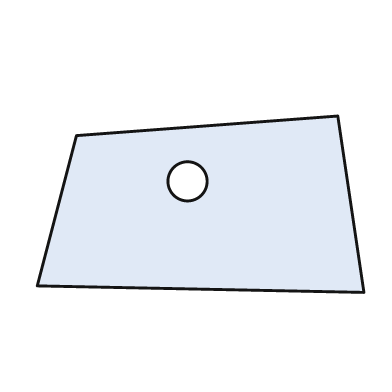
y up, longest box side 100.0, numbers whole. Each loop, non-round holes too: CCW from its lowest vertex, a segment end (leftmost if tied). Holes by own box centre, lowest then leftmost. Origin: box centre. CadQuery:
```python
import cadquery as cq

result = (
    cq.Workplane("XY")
    .moveTo(50.0, -27.0)
    .lineTo(42.0, 27.0)
    .lineTo(-38.0, 21.0)
    .lineTo(-50.0, -25.0)
    .close()
    .moveTo(-4.0, 7.0)
    .circle(6.0)
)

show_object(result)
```